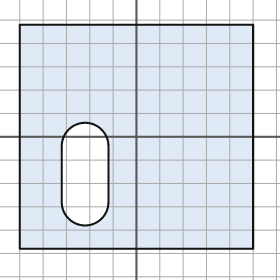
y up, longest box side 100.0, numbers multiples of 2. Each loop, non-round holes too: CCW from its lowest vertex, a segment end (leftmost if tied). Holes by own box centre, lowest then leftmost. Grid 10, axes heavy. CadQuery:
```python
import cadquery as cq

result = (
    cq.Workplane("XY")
    .moveTo(-50.0, -48.0)
    .lineTo(50.0, -48.0)
    .lineTo(50.0, 48.0)
    .lineTo(-50.0, 48.0)
    .close()
    .moveTo(-32.0, -28.0)
    .threePointArc((-22.0, -38.0), (-12.0, -28.0))
    .lineTo(-12.0, -4.0)
    .threePointArc((-22.0, 6.0), (-32.0, -4.0))
    .close()
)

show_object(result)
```